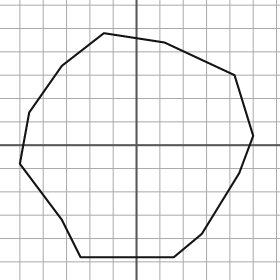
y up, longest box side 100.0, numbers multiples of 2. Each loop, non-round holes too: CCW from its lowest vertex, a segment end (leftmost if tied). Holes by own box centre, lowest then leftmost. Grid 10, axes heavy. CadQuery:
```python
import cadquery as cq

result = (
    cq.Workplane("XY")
    .moveTo(-24.0, -48.0)
    .lineTo(16.0, -48.0)
    .lineTo(28.0, -38.0)
    .lineTo(44.0, -12.0)
    .lineTo(50.0, 4.0)
    .lineTo(42.0, 30.0)
    .lineTo(12.0, 44.0)
    .lineTo(-14.0, 48.0)
    .lineTo(-32.0, 34.0)
    .lineTo(-46.0, 14.0)
    .lineTo(-50.0, -8.0)
    .lineTo(-32.0, -32.0)
    .close()
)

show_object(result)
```